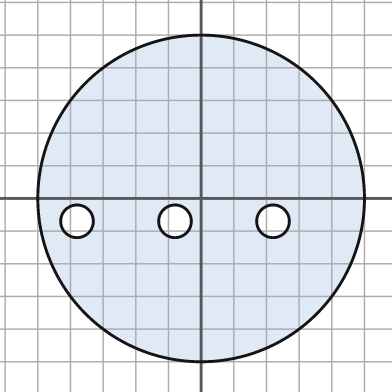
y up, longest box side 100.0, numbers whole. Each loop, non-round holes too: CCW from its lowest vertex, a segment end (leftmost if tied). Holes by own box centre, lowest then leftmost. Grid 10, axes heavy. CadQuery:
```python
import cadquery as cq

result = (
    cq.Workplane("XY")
    .moveTo(0.0, 0.0)
    .circle(50.0)
    .moveTo(-38.0, -7.0)
    .circle(5.0)
    .moveTo(-8.0, -7.0)
    .circle(5.0)
    .moveTo(22.0, -7.0)
    .circle(5.0)
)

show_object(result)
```